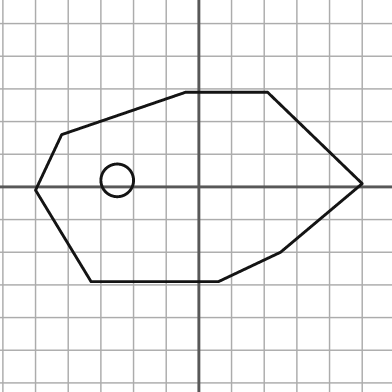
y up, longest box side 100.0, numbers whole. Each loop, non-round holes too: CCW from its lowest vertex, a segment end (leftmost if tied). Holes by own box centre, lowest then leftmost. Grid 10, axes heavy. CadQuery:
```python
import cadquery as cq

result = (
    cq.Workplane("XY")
    .moveTo(-33.0, -29.0)
    .lineTo(6.0, -29.0)
    .lineTo(25.0, -20.0)
    .lineTo(50.0, 1.0)
    .lineTo(21.0, 29.0)
    .lineTo(-4.0, 29.0)
    .lineTo(-42.0, 16.0)
    .lineTo(-50.0, -1.0)
    .close()
    .moveTo(-25.0, 2.0)
    .circle(5.0)
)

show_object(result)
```